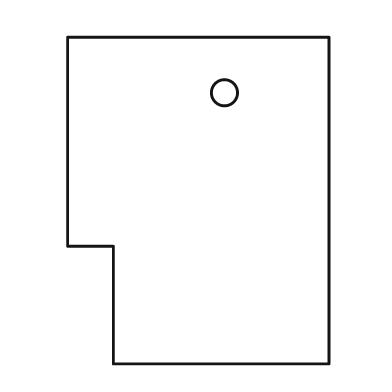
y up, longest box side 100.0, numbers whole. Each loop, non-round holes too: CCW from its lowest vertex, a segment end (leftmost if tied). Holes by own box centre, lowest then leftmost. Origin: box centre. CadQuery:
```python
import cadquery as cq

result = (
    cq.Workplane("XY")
    .moveTo(-26.0, -50.0)
    .lineTo(40.0, -50.0)
    .lineTo(40.0, 50.0)
    .lineTo(-40.0, 50.0)
    .lineTo(-40.0, -14.0)
    .lineTo(-26.0, -14.0)
    .close()
    .moveTo(8.0, 33.0)
    .circle(4.0)
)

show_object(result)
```